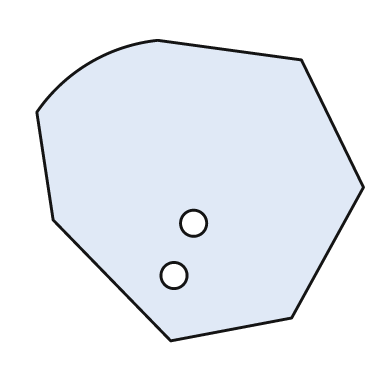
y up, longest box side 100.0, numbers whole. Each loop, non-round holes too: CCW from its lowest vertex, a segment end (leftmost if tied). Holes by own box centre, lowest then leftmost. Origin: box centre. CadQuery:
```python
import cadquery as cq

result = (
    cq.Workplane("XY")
    .moveTo(-9.0, -46.0)
    .lineTo(28.0, -39.0)
    .lineTo(50.0, 1.0)
    .lineTo(31.0, 40.0)
    .lineTo(-13.0, 46.0)
    .threePointArc((-34.0, 39.0), (-50.0, 24.0))
    .lineTo(-45.0, -9.0)
    .close()
    .moveTo(-8.0, -26.0)
    .circle(4.0)
    .moveTo(-2.0, -10.0)
    .circle(4.0)
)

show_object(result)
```